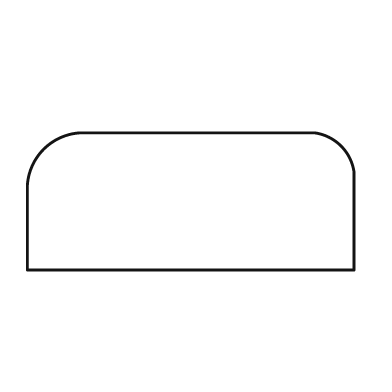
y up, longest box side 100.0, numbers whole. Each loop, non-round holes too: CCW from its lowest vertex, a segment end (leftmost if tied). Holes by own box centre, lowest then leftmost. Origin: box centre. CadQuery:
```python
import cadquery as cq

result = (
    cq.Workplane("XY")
    .moveTo(-50.0, -21.0)
    .lineTo(50.0, -21.0)
    .lineTo(50.0, 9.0)
    .threePointArc((46.0, 17.0), (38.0, 21.0))
    .lineTo(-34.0, 21.0)
    .threePointArc((-45.0, 16.0), (-50.0, 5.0))
    .close()
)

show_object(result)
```